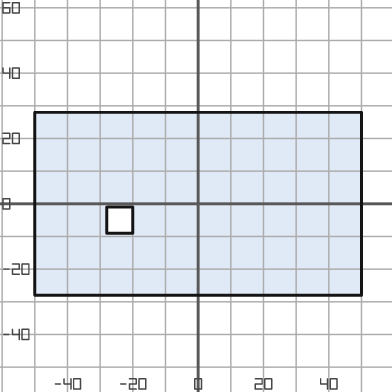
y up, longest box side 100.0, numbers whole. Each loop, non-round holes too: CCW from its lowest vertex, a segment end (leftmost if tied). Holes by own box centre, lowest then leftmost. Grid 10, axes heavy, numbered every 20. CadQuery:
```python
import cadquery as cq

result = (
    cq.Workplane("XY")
    .moveTo(-50.0, -28.0)
    .lineTo(50.0, -28.0)
    .lineTo(50.0, 28.0)
    .lineTo(-50.0, 28.0)
    .close()
    .moveTo(-28.0, -9.0)
    .lineTo(-20.0, -9.0)
    .lineTo(-20.0, -1.0)
    .lineTo(-28.0, -1.0)
    .close()
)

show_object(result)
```